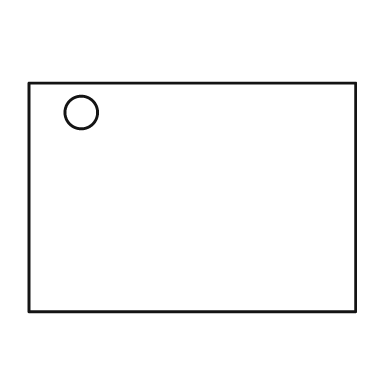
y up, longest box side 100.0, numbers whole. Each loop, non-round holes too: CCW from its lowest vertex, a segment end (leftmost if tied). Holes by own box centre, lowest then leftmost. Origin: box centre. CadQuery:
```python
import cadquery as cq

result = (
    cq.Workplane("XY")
    .moveTo(-50.0, -35.0)
    .lineTo(50.0, -35.0)
    .lineTo(50.0, 35.0)
    .lineTo(-50.0, 35.0)
    .close()
    .moveTo(-34.0, 26.0)
    .circle(5.0)
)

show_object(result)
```